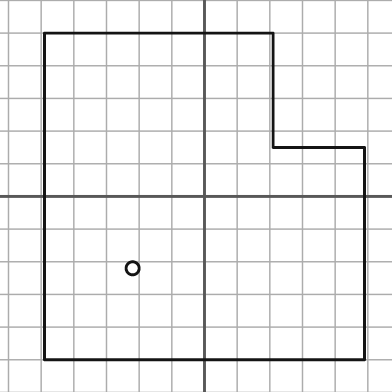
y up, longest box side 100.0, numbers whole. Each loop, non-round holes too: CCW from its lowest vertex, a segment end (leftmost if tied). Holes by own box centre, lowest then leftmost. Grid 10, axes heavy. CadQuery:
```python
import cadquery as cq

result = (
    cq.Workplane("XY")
    .moveTo(-49.0, -50.0)
    .lineTo(49.0, -50.0)
    .lineTo(49.0, 15.0)
    .lineTo(21.0, 15.0)
    .lineTo(21.0, 50.0)
    .lineTo(-49.0, 50.0)
    .close()
    .moveTo(-22.0, -22.0)
    .circle(2.0)
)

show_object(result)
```